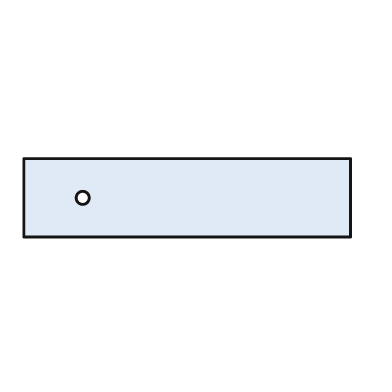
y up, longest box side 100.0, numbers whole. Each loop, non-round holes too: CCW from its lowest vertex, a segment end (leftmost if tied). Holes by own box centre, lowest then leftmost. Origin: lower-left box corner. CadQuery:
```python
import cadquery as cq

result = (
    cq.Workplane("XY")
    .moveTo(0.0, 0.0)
    .lineTo(100.0, 0.0)
    .lineTo(100.0, 24.0)
    .lineTo(0.0, 24.0)
    .close()
    .moveTo(18.0, 12.0)
    .circle(2.0)
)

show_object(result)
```